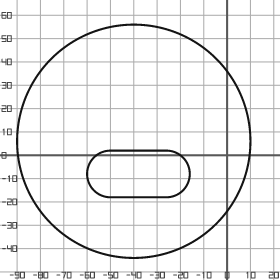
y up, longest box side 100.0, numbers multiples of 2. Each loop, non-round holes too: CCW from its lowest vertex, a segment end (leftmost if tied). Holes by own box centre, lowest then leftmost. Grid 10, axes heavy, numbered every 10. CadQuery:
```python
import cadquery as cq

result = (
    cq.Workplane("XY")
    .moveTo(-40.0, 6.0)
    .circle(50.0)
    .moveTo(-50.0, -18.0)
    .lineTo(-26.0, -18.0)
    .threePointArc((-16.0, -8.0), (-26.0, 2.0))
    .lineTo(-50.0, 2.0)
    .threePointArc((-60.0, -8.0), (-50.0, -18.0))
    .close()
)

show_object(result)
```